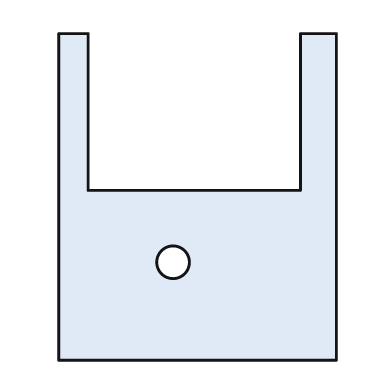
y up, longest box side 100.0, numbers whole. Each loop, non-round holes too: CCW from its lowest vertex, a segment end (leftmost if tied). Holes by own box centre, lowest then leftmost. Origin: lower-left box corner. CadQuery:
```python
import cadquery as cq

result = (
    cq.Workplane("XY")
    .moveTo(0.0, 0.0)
    .lineTo(85.0, 0.0)
    .lineTo(85.0, 100.0)
    .lineTo(74.0, 100.0)
    .lineTo(74.0, 52.0)
    .lineTo(9.0, 52.0)
    .lineTo(9.0, 100.0)
    .lineTo(0.0, 100.0)
    .close()
    .moveTo(35.0, 30.0)
    .circle(5.0)
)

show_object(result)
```